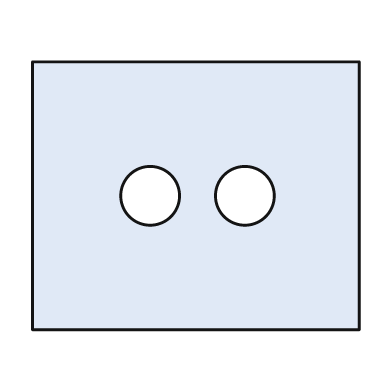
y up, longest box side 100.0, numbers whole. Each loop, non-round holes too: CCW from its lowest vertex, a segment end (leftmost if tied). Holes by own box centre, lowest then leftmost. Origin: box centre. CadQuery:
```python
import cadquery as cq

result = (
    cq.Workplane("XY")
    .moveTo(-50.0, -41.0)
    .lineTo(50.0, -41.0)
    .lineTo(50.0, 41.0)
    .lineTo(-50.0, 41.0)
    .close()
    .moveTo(-14.0, 0.0)
    .circle(9.0)
    .moveTo(15.0, 0.0)
    .circle(9.0)
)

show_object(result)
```